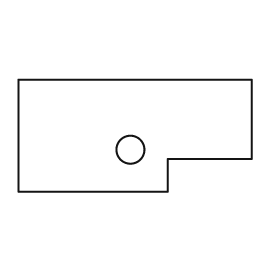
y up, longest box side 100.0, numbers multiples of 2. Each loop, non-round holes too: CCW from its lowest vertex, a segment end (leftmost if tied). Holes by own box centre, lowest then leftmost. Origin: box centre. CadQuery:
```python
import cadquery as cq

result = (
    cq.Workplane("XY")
    .moveTo(-50.0, -24.0)
    .lineTo(14.0, -24.0)
    .lineTo(14.0, -10.0)
    .lineTo(50.0, -10.0)
    .lineTo(50.0, 24.0)
    .lineTo(-50.0, 24.0)
    .close()
    .moveTo(-2.0, -6.0)
    .circle(6.0)
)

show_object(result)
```